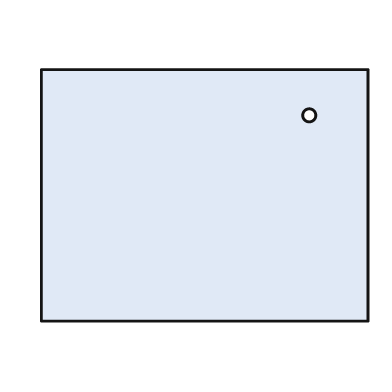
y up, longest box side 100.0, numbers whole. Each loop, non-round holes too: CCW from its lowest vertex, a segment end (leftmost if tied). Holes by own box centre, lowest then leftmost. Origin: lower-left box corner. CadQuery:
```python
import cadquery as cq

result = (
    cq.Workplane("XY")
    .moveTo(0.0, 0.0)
    .lineTo(100.0, 0.0)
    .lineTo(100.0, 77.0)
    .lineTo(0.0, 77.0)
    .close()
    .moveTo(82.0, 63.0)
    .circle(2.0)
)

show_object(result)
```